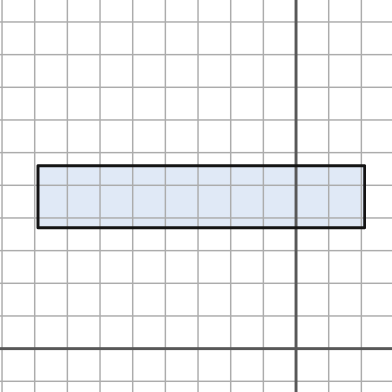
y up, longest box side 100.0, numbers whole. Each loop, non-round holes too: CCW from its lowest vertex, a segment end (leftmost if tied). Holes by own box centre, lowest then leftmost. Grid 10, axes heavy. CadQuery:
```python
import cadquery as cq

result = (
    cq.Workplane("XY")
    .moveTo(-79.0, 37.0)
    .lineTo(21.0, 37.0)
    .lineTo(21.0, 56.0)
    .lineTo(-79.0, 56.0)
    .close()
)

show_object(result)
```